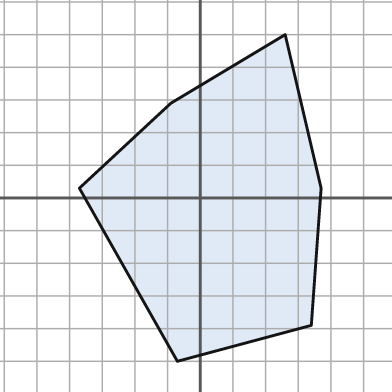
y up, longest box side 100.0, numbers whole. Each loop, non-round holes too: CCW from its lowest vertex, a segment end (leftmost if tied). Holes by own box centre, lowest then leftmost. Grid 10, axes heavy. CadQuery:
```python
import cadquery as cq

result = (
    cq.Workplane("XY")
    .moveTo(-7.0, -50.0)
    .lineTo(34.0, -39.0)
    .lineTo(37.0, 3.0)
    .lineTo(26.0, 50.0)
    .lineTo(-9.0, 29.0)
    .lineTo(-37.0, 3.0)
    .close()
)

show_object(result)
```